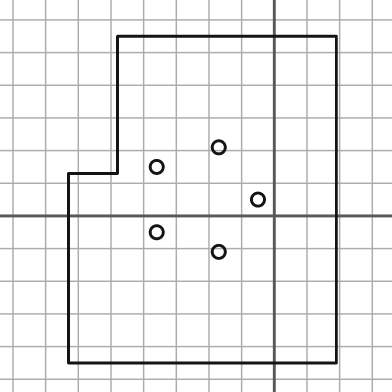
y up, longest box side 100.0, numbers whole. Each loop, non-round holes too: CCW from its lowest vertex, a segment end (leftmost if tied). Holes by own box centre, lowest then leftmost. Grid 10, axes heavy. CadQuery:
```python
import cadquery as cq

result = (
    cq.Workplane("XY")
    .moveTo(-63.0, -45.0)
    .lineTo(19.0, -45.0)
    .lineTo(19.0, 55.0)
    .lineTo(-48.0, 55.0)
    .lineTo(-48.0, 13.0)
    .lineTo(-63.0, 13.0)
    .close()
    .moveTo(-17.0, -11.0)
    .circle(2.0)
    .moveTo(-36.0, -5.0)
    .circle(2.0)
    .moveTo(-5.0, 5.0)
    .circle(2.0)
    .moveTo(-36.0, 15.0)
    .circle(2.0)
    .moveTo(-17.0, 21.0)
    .circle(2.0)
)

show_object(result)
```